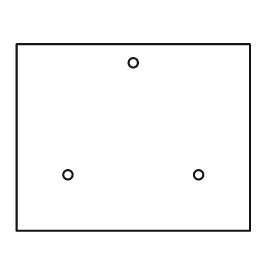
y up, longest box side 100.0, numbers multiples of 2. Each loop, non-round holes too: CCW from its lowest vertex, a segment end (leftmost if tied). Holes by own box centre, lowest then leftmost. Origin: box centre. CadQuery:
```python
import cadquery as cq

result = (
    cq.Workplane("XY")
    .moveTo(-50.0, -40.0)
    .lineTo(50.0, -40.0)
    .lineTo(50.0, 40.0)
    .lineTo(-50.0, 40.0)
    .close()
    .moveTo(-28.0, -16.0)
    .circle(2.0)
    .moveTo(28.0, -16.0)
    .circle(2.0)
    .moveTo(0.0, 32.0)
    .circle(2.0)
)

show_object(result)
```